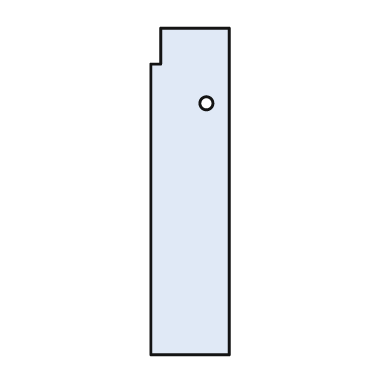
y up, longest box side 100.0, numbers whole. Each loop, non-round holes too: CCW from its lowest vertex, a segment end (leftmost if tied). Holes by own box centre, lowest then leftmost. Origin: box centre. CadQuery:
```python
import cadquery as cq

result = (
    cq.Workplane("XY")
    .moveTo(-12.0, -50.0)
    .lineTo(12.0, -50.0)
    .lineTo(12.0, 50.0)
    .lineTo(-9.0, 50.0)
    .lineTo(-9.0, 39.0)
    .lineTo(-12.0, 39.0)
    .close()
    .moveTo(5.0, 27.0)
    .circle(2.0)
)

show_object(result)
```